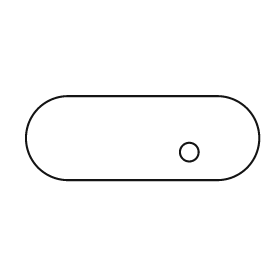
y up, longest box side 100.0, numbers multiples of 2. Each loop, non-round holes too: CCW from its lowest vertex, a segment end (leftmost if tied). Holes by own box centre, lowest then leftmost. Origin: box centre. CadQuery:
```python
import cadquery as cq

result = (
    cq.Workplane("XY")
    .moveTo(-32.0, -18.0)
    .lineTo(32.0, -18.0)
    .threePointArc((50.0, 0.0), (32.0, 18.0))
    .lineTo(-32.0, 18.0)
    .threePointArc((-50.0, 0.0), (-32.0, -18.0))
    .close()
    .moveTo(20.0, -6.0)
    .circle(4.0)
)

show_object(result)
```